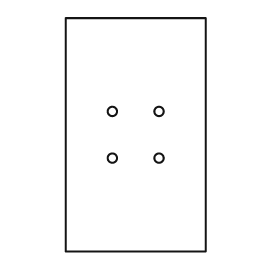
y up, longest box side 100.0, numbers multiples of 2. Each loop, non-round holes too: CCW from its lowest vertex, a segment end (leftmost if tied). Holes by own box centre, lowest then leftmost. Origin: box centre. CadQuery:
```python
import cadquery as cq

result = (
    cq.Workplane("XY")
    .moveTo(-30.0, -50.0)
    .lineTo(30.0, -50.0)
    .lineTo(30.0, 50.0)
    .lineTo(-30.0, 50.0)
    .close()
    .moveTo(-10.0, -10.0)
    .circle(2.0)
    .moveTo(10.0, -10.0)
    .circle(2.0)
    .moveTo(-10.0, 10.0)
    .circle(2.0)
    .moveTo(10.0, 10.0)
    .circle(2.0)
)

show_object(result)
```